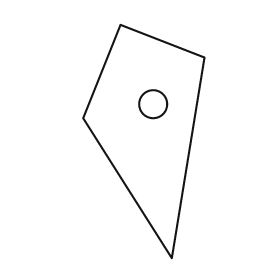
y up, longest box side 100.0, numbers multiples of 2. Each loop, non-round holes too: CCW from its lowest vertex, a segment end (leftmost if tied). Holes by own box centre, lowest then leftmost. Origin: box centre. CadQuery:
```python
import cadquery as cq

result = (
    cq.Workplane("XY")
    .moveTo(12.0, -50.0)
    .lineTo(26.0, 36.0)
    .lineTo(-10.0, 50.0)
    .lineTo(-26.0, 10.0)
    .close()
    .moveTo(4.0, 16.0)
    .circle(6.0)
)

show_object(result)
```